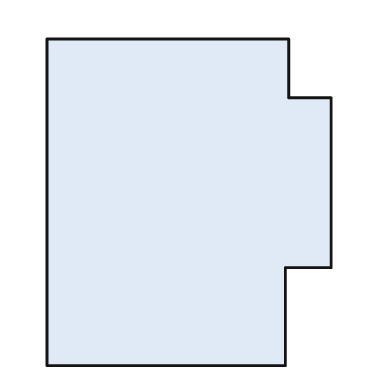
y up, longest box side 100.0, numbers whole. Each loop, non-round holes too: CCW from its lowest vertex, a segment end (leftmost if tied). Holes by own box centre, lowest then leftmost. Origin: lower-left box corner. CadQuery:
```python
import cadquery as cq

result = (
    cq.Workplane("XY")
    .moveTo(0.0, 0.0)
    .lineTo(73.0, 0.0)
    .lineTo(73.0, 30.0)
    .lineTo(87.0, 30.0)
    .lineTo(87.0, 82.0)
    .lineTo(74.0, 82.0)
    .lineTo(74.0, 100.0)
    .lineTo(0.0, 100.0)
    .close()
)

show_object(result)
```